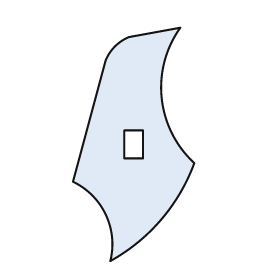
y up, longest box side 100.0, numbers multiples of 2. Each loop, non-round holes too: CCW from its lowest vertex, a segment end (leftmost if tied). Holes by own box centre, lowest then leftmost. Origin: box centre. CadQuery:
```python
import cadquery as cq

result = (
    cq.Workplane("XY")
    .moveTo(-10.0, -50.0)
    .threePointArc((12.0, -32.0), (26.0, -8.0))
    .threePointArc((12.0, 20.0), (20.0, 50.0))
    .lineTo(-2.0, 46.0)
    .threePointArc((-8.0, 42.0), (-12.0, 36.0))
    .lineTo(-26.0, -16.0)
    .threePointArc((-12.0, -30.0), (-10.0, -50.0))
    .close()
    .moveTo(-4.0, -6.0)
    .lineTo(4.0, -6.0)
    .lineTo(4.0, 6.0)
    .lineTo(-4.0, 6.0)
    .close()
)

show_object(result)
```